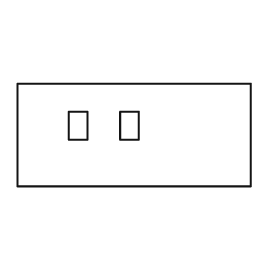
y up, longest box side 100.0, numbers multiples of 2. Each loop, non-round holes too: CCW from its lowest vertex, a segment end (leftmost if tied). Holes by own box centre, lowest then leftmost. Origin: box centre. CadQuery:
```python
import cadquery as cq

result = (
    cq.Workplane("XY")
    .moveTo(-50.0, -22.0)
    .lineTo(50.0, -22.0)
    .lineTo(50.0, 22.0)
    .lineTo(-50.0, 22.0)
    .close()
    .moveTo(-28.0, -2.0)
    .lineTo(-20.0, -2.0)
    .lineTo(-20.0, 10.0)
    .lineTo(-28.0, 10.0)
    .close()
    .moveTo(-6.0, -2.0)
    .lineTo(2.0, -2.0)
    .lineTo(2.0, 10.0)
    .lineTo(-6.0, 10.0)
    .close()
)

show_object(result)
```